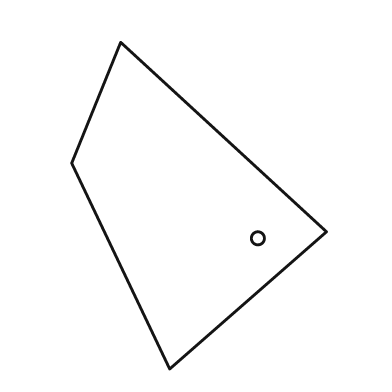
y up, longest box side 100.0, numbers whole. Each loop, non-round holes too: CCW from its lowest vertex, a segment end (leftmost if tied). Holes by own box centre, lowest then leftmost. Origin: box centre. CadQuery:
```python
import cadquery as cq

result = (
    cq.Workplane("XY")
    .moveTo(-9.0, -50.0)
    .lineTo(39.0, -8.0)
    .lineTo(-24.0, 50.0)
    .lineTo(-39.0, 13.0)
    .close()
    .moveTo(18.0, -10.0)
    .circle(2.0)
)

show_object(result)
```